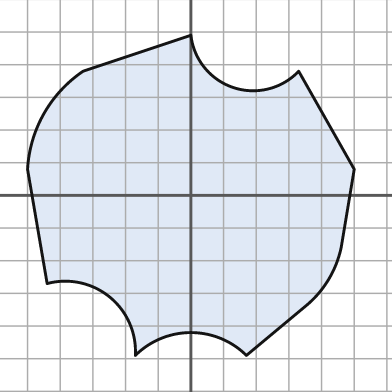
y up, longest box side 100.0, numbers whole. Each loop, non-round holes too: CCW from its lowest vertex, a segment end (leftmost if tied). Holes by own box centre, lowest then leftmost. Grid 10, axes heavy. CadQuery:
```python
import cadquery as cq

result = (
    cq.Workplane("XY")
    .moveTo(-17.0, -49.0)
    .threePointArc((0.0, -42.0), (17.0, -49.0))
    .lineTo(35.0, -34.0)
    .threePointArc((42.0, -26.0), (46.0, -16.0))
    .lineTo(50.0, 8.0)
    .lineTo(33.0, 38.0)
    .threePointArc((13.0, 33.0), (0.0, 49.0))
    .lineTo(-33.0, 38.0)
    .threePointArc((-45.0, 25.0), (-50.0, 8.0))
    .lineTo(-44.0, -27.0)
    .threePointArc((-25.0, -31.0), (-17.0, -49.0))
    .close()
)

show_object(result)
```